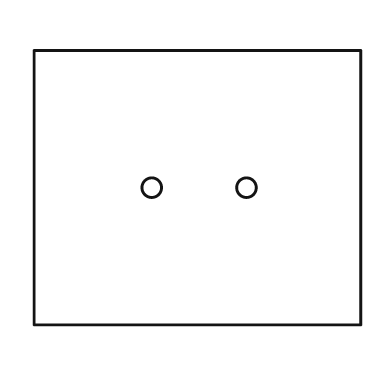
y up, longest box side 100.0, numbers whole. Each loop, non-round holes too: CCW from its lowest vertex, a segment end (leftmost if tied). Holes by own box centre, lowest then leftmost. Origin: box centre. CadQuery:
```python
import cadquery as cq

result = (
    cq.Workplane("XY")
    .moveTo(-50.0, -42.0)
    .lineTo(50.0, -42.0)
    .lineTo(50.0, 42.0)
    .lineTo(-50.0, 42.0)
    .close()
    .moveTo(-14.0, 0.0)
    .circle(3.0)
    .moveTo(15.0, 0.0)
    .circle(3.0)
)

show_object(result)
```